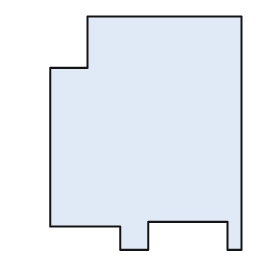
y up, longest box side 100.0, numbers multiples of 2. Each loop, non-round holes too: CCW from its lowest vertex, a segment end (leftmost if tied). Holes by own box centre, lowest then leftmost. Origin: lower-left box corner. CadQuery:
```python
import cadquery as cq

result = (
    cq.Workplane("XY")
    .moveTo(30.0, 0.0)
    .lineTo(42.0, 0.0)
    .lineTo(42.0, 12.0)
    .lineTo(76.0, 12.0)
    .lineTo(76.0, 0.0)
    .lineTo(82.0, 0.0)
    .lineTo(82.0, 100.0)
    .lineTo(16.0, 100.0)
    .lineTo(16.0, 78.0)
    .lineTo(0.0, 78.0)
    .lineTo(0.0, 10.0)
    .lineTo(30.0, 10.0)
    .close()
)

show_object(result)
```